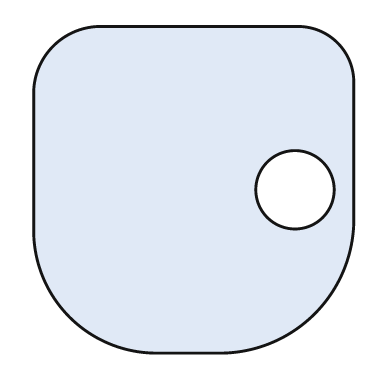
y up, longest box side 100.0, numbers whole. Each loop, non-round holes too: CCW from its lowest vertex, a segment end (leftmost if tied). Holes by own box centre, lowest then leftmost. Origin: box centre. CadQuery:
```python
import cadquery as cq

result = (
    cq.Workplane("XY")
    .moveTo(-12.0, -50.0)
    .lineTo(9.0, -50.0)
    .threePointArc((37.0, -38.0), (49.0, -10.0))
    .lineTo(49.0, 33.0)
    .threePointArc((44.0, 45.0), (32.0, 50.0))
    .lineTo(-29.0, 50.0)
    .threePointArc((-43.0, 44.0), (-49.0, 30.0))
    .lineTo(-49.0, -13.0)
    .threePointArc((-38.0, -39.0), (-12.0, -50.0))
    .close()
    .moveTo(31.0, 0.0)
    .circle(12.0)
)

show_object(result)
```